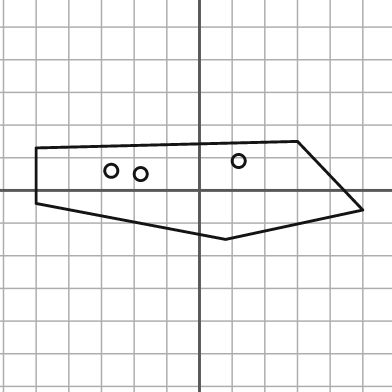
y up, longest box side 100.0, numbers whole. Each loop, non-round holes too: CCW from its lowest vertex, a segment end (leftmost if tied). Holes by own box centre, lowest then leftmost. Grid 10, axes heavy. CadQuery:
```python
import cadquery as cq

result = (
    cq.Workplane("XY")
    .moveTo(8.0, -15.0)
    .lineTo(50.0, -6.0)
    .lineTo(30.0, 15.0)
    .lineTo(-50.0, 13.0)
    .lineTo(-50.0, -4.0)
    .close()
    .moveTo(-18.0, 5.0)
    .circle(2.0)
    .moveTo(-27.0, 6.0)
    .circle(2.0)
    .moveTo(12.0, 9.0)
    .circle(2.0)
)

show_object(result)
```